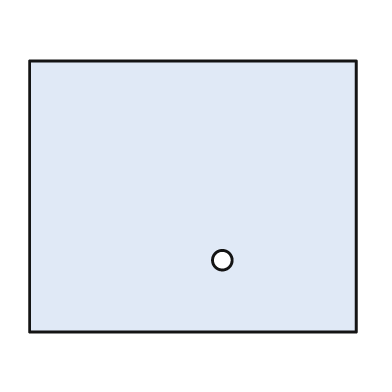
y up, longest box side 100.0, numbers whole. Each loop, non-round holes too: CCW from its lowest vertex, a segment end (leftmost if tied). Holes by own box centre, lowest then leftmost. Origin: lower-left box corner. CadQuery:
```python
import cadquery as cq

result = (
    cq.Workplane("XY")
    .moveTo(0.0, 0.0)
    .lineTo(100.0, 0.0)
    .lineTo(100.0, 83.0)
    .lineTo(0.0, 83.0)
    .close()
    .moveTo(59.0, 22.0)
    .circle(3.0)
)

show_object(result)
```